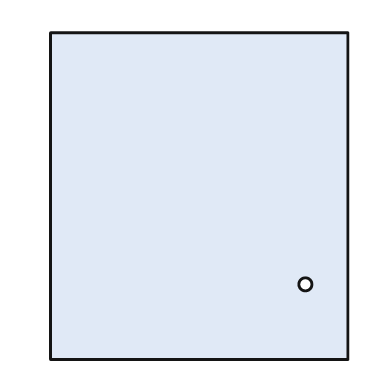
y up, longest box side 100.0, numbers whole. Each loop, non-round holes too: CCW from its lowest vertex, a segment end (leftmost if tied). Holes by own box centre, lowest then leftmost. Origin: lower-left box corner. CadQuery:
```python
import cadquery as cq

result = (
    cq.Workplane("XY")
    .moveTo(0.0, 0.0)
    .lineTo(91.0, 0.0)
    .lineTo(91.0, 100.0)
    .lineTo(0.0, 100.0)
    .close()
    .moveTo(78.0, 23.0)
    .circle(2.0)
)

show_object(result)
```